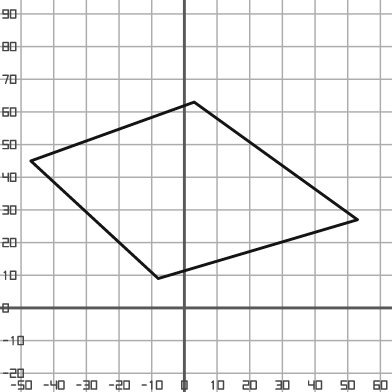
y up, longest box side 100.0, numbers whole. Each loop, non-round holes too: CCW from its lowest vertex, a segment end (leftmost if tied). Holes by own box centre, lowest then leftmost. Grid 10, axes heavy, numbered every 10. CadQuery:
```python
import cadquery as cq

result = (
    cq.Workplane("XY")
    .moveTo(-8.0, 9.0)
    .lineTo(53.0, 27.0)
    .lineTo(3.0, 63.0)
    .lineTo(-47.0, 45.0)
    .close()
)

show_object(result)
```